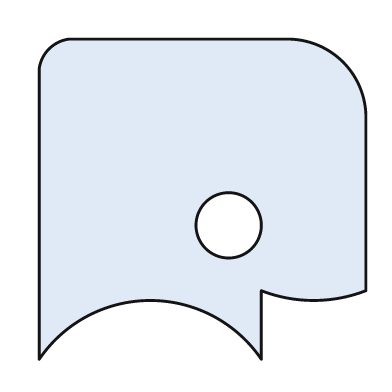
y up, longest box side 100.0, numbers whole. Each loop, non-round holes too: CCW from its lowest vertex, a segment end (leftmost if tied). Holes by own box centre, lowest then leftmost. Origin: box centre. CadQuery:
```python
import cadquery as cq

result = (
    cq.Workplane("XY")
    .moveTo(-50.0, -49.0)
    .threePointArc((-16.0, -31.0), (18.0, -49.0))
    .lineTo(18.0, -28.0)
    .threePointArc((34.0, -31.0), (50.0, -28.0))
    .lineTo(50.0, 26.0)
    .threePointArc((43.0, 42.0), (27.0, 49.0))
    .lineTo(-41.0, 49.0)
    .threePointArc((-47.0, 46.0), (-50.0, 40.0))
    .close()
    .moveTo(8.0, -8.0)
    .circle(10.0)
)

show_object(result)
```